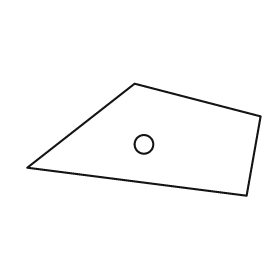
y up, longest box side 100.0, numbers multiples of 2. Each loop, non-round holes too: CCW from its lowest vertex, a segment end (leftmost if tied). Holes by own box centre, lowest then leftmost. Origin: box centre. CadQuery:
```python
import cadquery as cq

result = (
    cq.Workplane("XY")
    .moveTo(44.0, -24.0)
    .lineTo(50.0, 10.0)
    .lineTo(-4.0, 24.0)
    .lineTo(-50.0, -12.0)
    .close()
    .moveTo(0.0, -2.0)
    .circle(4.0)
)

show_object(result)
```